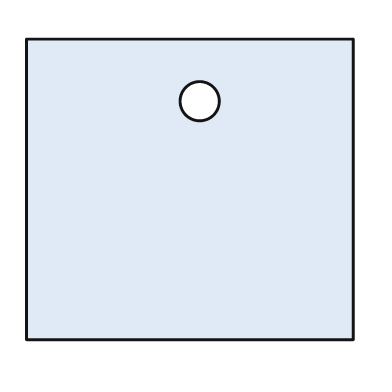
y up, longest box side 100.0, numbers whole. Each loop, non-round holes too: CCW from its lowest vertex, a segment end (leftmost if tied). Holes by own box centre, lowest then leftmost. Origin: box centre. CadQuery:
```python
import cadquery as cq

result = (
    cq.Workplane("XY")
    .moveTo(-50.0, -46.0)
    .lineTo(50.0, -46.0)
    .lineTo(50.0, 46.0)
    .lineTo(-50.0, 46.0)
    .close()
    .moveTo(3.0, 27.0)
    .circle(6.0)
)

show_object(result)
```